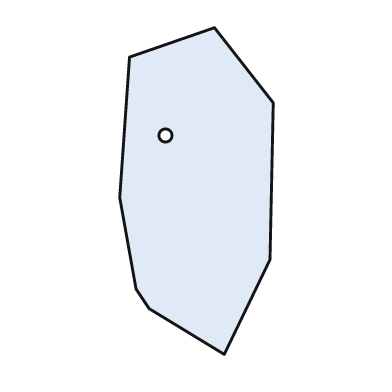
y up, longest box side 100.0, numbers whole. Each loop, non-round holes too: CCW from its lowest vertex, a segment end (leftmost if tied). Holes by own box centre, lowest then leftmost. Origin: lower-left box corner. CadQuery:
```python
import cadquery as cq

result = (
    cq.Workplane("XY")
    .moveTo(32.0, 0.0)
    .lineTo(46.0, 29.0)
    .lineTo(47.0, 77.0)
    .lineTo(29.0, 100.0)
    .lineTo(3.0, 91.0)
    .lineTo(0.0, 48.0)
    .lineTo(5.0, 20.0)
    .lineTo(9.0, 14.0)
    .close()
    .moveTo(14.0, 67.0)
    .circle(2.0)
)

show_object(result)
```